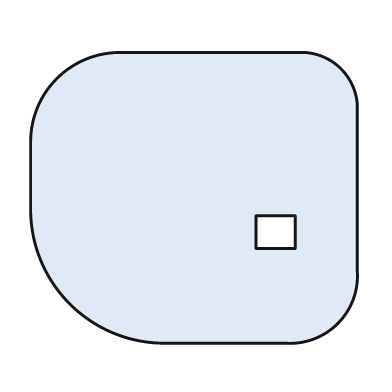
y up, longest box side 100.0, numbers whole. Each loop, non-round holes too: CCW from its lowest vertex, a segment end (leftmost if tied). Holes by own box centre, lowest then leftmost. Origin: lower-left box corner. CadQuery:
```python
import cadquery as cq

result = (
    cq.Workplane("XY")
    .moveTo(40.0, 0.0)
    .lineTo(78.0, 0.0)
    .threePointArc((94.0, 6.0), (100.0, 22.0))
    .lineTo(100.0, 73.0)
    .threePointArc((95.0, 84.0), (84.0, 89.0))
    .lineTo(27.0, 89.0)
    .threePointArc((8.0, 81.0), (0.0, 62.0))
    .lineTo(0.0, 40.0)
    .threePointArc((12.0, 12.0), (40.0, 0.0))
    .close()
    .moveTo(69.0, 29.0)
    .lineTo(81.0, 29.0)
    .lineTo(81.0, 39.0)
    .lineTo(69.0, 39.0)
    .close()
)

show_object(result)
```